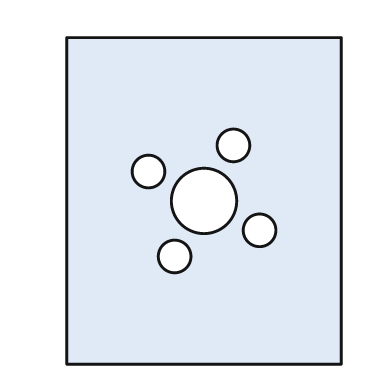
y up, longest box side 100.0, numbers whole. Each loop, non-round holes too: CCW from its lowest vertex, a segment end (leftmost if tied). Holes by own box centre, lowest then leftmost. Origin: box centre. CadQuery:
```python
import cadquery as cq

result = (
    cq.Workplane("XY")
    .moveTo(-42.0, -50.0)
    .lineTo(42.0, -50.0)
    .lineTo(42.0, 50.0)
    .lineTo(-42.0, 50.0)
    .close()
    .moveTo(-9.0, -17.0)
    .circle(5.0)
    .moveTo(17.0, -9.0)
    .circle(5.0)
    .moveTo(0.0, 0.0)
    .circle(10.0)
    .moveTo(-17.0, 9.0)
    .circle(5.0)
    .moveTo(9.0, 17.0)
    .circle(5.0)
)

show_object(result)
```